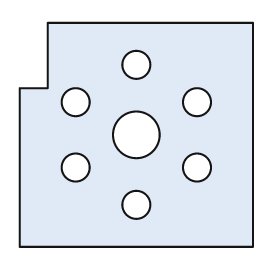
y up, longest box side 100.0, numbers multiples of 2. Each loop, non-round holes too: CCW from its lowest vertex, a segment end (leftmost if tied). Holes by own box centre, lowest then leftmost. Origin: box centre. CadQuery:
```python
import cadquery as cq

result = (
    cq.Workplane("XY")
    .moveTo(-50.0, -48.0)
    .lineTo(50.0, -48.0)
    .lineTo(50.0, 48.0)
    .lineTo(-38.0, 48.0)
    .lineTo(-38.0, 20.0)
    .lineTo(-50.0, 20.0)
    .close()
    .moveTo(0.0, -30.0)
    .circle(6.0)
    .moveTo(-26.0, -14.0)
    .circle(6.0)
    .moveTo(26.0, -14.0)
    .circle(6.0)
    .moveTo(0.0, 0.0)
    .circle(10.0)
    .moveTo(-26.0, 14.0)
    .circle(6.0)
    .moveTo(26.0, 14.0)
    .circle(6.0)
    .moveTo(0.0, 30.0)
    .circle(6.0)
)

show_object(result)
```